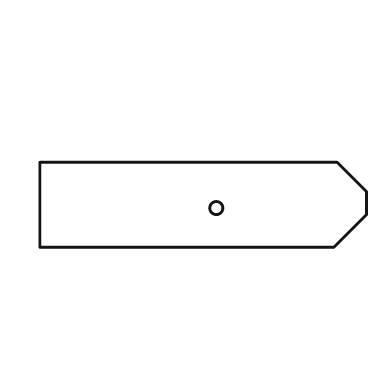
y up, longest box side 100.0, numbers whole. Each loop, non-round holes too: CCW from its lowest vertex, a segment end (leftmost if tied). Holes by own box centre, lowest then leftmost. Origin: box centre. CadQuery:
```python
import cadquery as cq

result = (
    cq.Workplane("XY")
    .moveTo(-50.0, -13.0)
    .lineTo(40.0, -13.0)
    .lineTo(50.0, -3.0)
    .lineTo(50.0, 4.0)
    .lineTo(41.0, 13.0)
    .lineTo(-50.0, 13.0)
    .close()
    .moveTo(4.0, -1.0)
    .circle(2.0)
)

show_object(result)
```